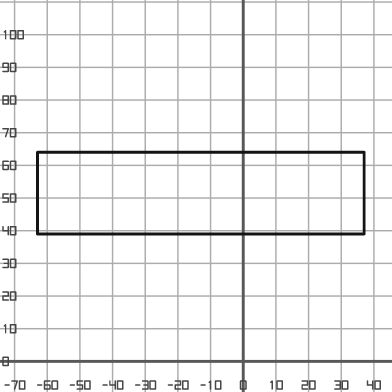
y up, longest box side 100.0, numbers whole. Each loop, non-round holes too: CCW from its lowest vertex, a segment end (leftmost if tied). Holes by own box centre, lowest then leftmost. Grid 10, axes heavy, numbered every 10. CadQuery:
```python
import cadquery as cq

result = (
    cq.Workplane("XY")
    .moveTo(-63.0, 39.0)
    .lineTo(37.0, 39.0)
    .lineTo(37.0, 64.0)
    .lineTo(-63.0, 64.0)
    .close()
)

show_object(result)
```